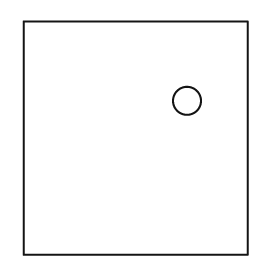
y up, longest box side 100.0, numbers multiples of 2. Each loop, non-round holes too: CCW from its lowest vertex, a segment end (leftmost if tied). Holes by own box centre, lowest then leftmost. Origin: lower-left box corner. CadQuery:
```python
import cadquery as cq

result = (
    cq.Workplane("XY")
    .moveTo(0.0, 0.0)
    .lineTo(96.0, 0.0)
    .lineTo(96.0, 100.0)
    .lineTo(0.0, 100.0)
    .close()
    .moveTo(70.0, 66.0)
    .circle(6.0)
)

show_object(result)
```